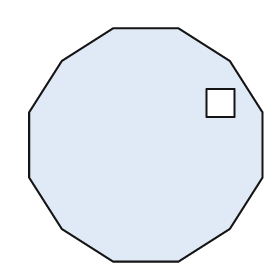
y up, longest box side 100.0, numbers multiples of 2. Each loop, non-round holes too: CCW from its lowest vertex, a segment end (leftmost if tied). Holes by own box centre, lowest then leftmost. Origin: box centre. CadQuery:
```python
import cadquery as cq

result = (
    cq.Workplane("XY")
    .moveTo(-14.0, -50.0)
    .lineTo(14.0, -50.0)
    .lineTo(36.0, -36.0)
    .lineTo(50.0, -14.0)
    .lineTo(50.0, 14.0)
    .lineTo(36.0, 36.0)
    .lineTo(14.0, 50.0)
    .lineTo(-14.0, 50.0)
    .lineTo(-36.0, 36.0)
    .lineTo(-50.0, 14.0)
    .lineTo(-50.0, -14.0)
    .lineTo(-36.0, -36.0)
    .close()
    .moveTo(26.0, 12.0)
    .lineTo(38.0, 12.0)
    .lineTo(38.0, 24.0)
    .lineTo(26.0, 24.0)
    .close()
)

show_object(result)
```